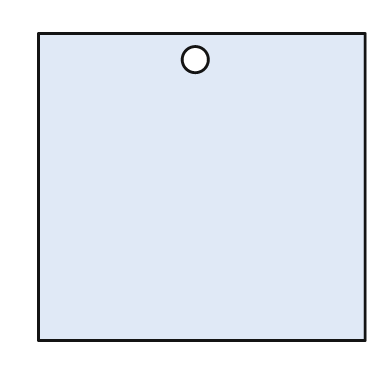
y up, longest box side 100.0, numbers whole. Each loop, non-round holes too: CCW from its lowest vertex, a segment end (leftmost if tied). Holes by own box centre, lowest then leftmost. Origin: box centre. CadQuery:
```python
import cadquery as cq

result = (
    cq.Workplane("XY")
    .moveTo(-50.0, -47.0)
    .lineTo(50.0, -47.0)
    .lineTo(50.0, 47.0)
    .lineTo(-50.0, 47.0)
    .close()
    .moveTo(-2.0, 39.0)
    .circle(4.0)
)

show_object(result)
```